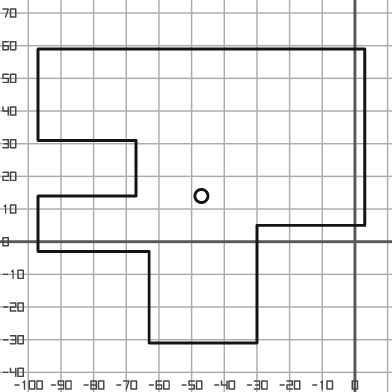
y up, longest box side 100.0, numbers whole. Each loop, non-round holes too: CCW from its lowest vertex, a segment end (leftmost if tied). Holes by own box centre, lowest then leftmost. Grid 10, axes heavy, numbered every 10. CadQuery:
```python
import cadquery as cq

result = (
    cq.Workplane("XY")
    .moveTo(-63.0, -31.0)
    .lineTo(-30.0, -31.0)
    .lineTo(-30.0, 5.0)
    .lineTo(3.0, 5.0)
    .lineTo(3.0, 59.0)
    .lineTo(-97.0, 59.0)
    .lineTo(-97.0, 31.0)
    .lineTo(-67.0, 31.0)
    .lineTo(-67.0, 14.0)
    .lineTo(-97.0, 14.0)
    .lineTo(-97.0, -3.0)
    .lineTo(-63.0, -3.0)
    .close()
    .moveTo(-47.0, 14.0)
    .circle(2.0)
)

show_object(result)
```